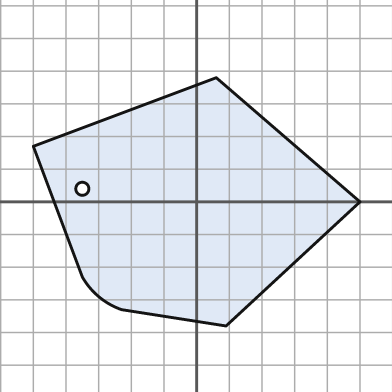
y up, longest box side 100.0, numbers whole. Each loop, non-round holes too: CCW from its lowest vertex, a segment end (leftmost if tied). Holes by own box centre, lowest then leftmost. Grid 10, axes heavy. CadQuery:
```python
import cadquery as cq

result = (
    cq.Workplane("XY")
    .moveTo(9.0, -38.0)
    .lineTo(50.0, 0.0)
    .lineTo(6.0, 38.0)
    .lineTo(-50.0, 17.0)
    .lineTo(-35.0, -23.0)
    .threePointArc((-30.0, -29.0), (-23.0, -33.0))
    .close()
    .moveTo(-35.0, 4.0)
    .circle(2.0)
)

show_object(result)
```